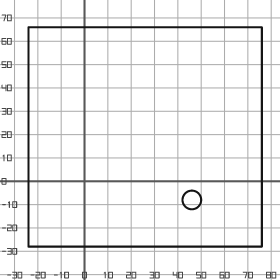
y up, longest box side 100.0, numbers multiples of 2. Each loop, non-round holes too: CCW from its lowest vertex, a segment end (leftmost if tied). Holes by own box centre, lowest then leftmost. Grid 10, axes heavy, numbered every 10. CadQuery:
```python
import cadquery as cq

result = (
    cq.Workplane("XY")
    .moveTo(-24.0, -28.0)
    .lineTo(76.0, -28.0)
    .lineTo(76.0, 66.0)
    .lineTo(-24.0, 66.0)
    .close()
    .moveTo(46.0, -8.0)
    .circle(4.0)
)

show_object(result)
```